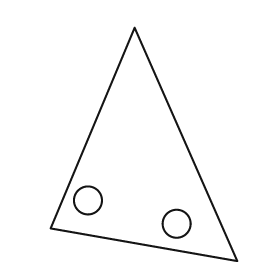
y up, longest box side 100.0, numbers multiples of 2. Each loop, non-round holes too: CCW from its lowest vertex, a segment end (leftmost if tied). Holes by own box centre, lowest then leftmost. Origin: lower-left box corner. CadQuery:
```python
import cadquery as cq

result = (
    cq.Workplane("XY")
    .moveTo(80.0, 0.0)
    .lineTo(36.0, 100.0)
    .lineTo(0.0, 14.0)
    .close()
    .moveTo(54.0, 16.0)
    .circle(6.0)
    .moveTo(16.0, 26.0)
    .circle(6.0)
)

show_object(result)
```